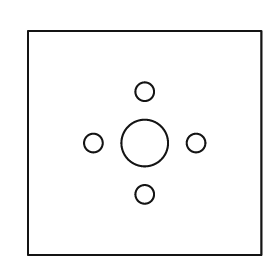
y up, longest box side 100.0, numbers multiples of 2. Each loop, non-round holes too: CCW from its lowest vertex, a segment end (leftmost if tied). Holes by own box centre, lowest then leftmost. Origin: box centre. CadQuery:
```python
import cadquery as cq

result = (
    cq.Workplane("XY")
    .moveTo(-50.0, -48.0)
    .lineTo(50.0, -48.0)
    .lineTo(50.0, 48.0)
    .lineTo(-50.0, 48.0)
    .close()
    .moveTo(0.0, -22.0)
    .circle(4.0)
    .moveTo(-22.0, 0.0)
    .circle(4.0)
    .moveTo(0.0, 0.0)
    .circle(10.0)
    .moveTo(22.0, 0.0)
    .circle(4.0)
    .moveTo(0.0, 22.0)
    .circle(4.0)
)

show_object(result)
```